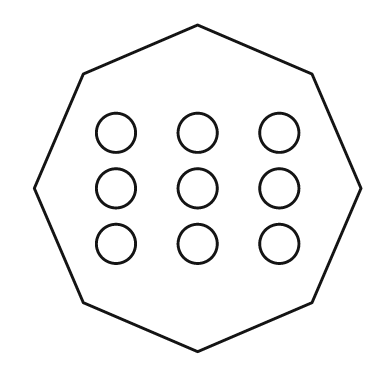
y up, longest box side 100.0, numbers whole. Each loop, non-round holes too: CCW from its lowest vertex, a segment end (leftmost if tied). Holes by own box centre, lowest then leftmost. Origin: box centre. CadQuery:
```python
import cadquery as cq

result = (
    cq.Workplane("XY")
    .moveTo(0.0, -50.0)
    .lineTo(35.0, -35.0)
    .lineTo(50.0, 0.0)
    .lineTo(35.0, 35.0)
    .lineTo(0.0, 50.0)
    .lineTo(-35.0, 35.0)
    .lineTo(-50.0, 0.0)
    .lineTo(-35.0, -35.0)
    .close()
    .moveTo(-25.0, -17.0)
    .circle(6.0)
    .moveTo(0.0, -17.0)
    .circle(6.0)
    .moveTo(25.0, -17.0)
    .circle(6.0)
    .moveTo(-25.0, 0.0)
    .circle(6.0)
    .moveTo(0.0, 0.0)
    .circle(6.0)
    .moveTo(25.0, 0.0)
    .circle(6.0)
    .moveTo(-25.0, 17.0)
    .circle(6.0)
    .moveTo(0.0, 17.0)
    .circle(6.0)
    .moveTo(25.0, 17.0)
    .circle(6.0)
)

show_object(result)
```